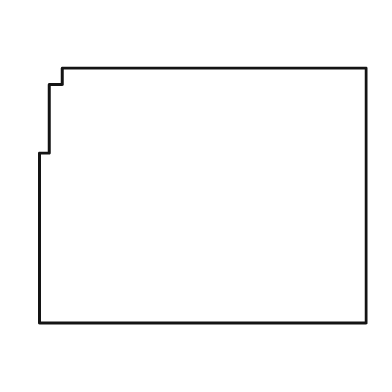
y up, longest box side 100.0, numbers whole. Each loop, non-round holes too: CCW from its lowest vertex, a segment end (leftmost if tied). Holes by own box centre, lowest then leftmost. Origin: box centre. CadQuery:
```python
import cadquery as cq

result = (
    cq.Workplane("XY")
    .moveTo(-50.0, -39.0)
    .lineTo(50.0, -39.0)
    .lineTo(50.0, 39.0)
    .lineTo(-43.0, 39.0)
    .lineTo(-43.0, 34.0)
    .lineTo(-47.0, 34.0)
    .lineTo(-47.0, 13.0)
    .lineTo(-50.0, 13.0)
    .close()
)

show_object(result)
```